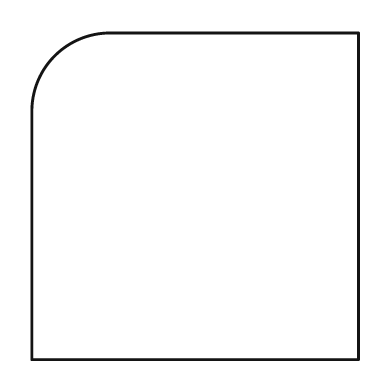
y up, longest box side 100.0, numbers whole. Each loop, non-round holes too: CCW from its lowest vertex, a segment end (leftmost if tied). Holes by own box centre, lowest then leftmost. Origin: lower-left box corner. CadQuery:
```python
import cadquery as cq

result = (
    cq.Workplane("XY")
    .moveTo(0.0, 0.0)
    .lineTo(100.0, 0.0)
    .lineTo(100.0, 100.0)
    .lineTo(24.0, 100.0)
    .threePointArc((7.0, 93.0), (0.0, 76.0))
    .close()
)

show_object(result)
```